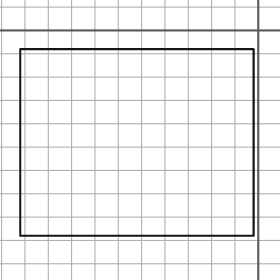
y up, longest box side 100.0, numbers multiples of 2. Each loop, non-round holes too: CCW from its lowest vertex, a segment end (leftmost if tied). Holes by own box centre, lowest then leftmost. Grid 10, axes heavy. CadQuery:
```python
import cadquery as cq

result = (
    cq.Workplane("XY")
    .moveTo(-102.0, -88.0)
    .lineTo(-2.0, -88.0)
    .lineTo(-2.0, -8.0)
    .lineTo(-102.0, -8.0)
    .close()
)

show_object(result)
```